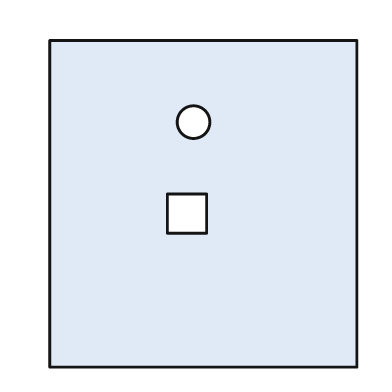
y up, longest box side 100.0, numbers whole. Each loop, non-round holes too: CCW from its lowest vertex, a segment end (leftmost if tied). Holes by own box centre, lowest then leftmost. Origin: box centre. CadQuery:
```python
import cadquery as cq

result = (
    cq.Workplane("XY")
    .moveTo(-47.0, -50.0)
    .lineTo(47.0, -50.0)
    .lineTo(47.0, 50.0)
    .lineTo(-47.0, 50.0)
    .close()
    .moveTo(-11.0, -9.0)
    .lineTo(1.0, -9.0)
    .lineTo(1.0, 3.0)
    .lineTo(-11.0, 3.0)
    .close()
    .moveTo(-3.0, 25.0)
    .circle(5.0)
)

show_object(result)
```